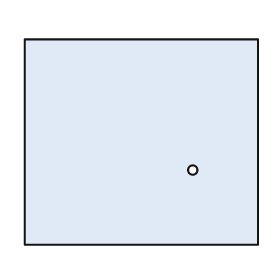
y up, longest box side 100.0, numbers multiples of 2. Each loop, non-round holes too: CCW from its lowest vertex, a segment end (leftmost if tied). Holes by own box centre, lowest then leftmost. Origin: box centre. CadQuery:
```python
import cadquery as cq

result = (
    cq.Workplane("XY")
    .moveTo(-50.0, -44.0)
    .lineTo(50.0, -44.0)
    .lineTo(50.0, 44.0)
    .lineTo(-50.0, 44.0)
    .close()
    .moveTo(22.0, -12.0)
    .circle(2.0)
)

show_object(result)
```